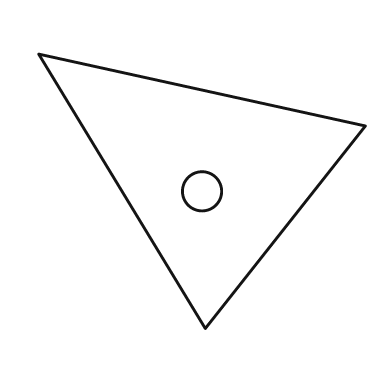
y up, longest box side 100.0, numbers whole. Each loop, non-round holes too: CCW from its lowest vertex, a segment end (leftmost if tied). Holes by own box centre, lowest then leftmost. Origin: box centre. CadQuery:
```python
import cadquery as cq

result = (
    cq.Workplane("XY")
    .moveTo(1.0, -42.0)
    .lineTo(50.0, 20.0)
    .lineTo(-50.0, 42.0)
    .close()
    .moveTo(0.0, 0.0)
    .circle(6.0)
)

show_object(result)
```